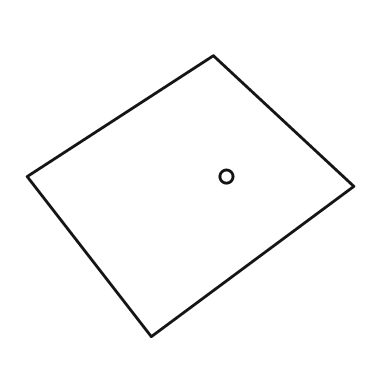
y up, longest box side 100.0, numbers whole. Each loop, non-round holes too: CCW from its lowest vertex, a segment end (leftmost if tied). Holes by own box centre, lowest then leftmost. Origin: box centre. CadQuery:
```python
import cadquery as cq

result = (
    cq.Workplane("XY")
    .moveTo(-12.0, -43.0)
    .lineTo(50.0, 3.0)
    .lineTo(7.0, 43.0)
    .lineTo(-50.0, 6.0)
    .close()
    .moveTo(11.0, 6.0)
    .circle(2.0)
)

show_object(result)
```